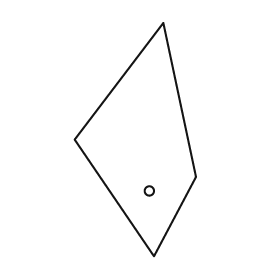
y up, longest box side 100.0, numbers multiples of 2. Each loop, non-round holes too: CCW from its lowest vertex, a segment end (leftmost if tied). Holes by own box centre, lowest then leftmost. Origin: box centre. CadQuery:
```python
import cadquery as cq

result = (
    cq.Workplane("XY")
    .moveTo(8.0, -50.0)
    .lineTo(26.0, -16.0)
    .lineTo(12.0, 50.0)
    .lineTo(-26.0, 0.0)
    .close()
    .moveTo(6.0, -22.0)
    .circle(2.0)
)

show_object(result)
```